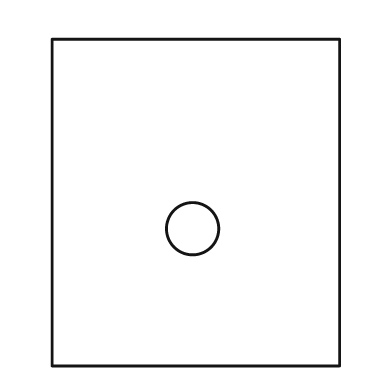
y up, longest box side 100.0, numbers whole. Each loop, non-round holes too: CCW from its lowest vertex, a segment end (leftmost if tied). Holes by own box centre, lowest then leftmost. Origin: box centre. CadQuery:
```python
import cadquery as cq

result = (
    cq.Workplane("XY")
    .moveTo(-44.0, -50.0)
    .lineTo(44.0, -50.0)
    .lineTo(44.0, 50.0)
    .lineTo(-44.0, 50.0)
    .close()
    .moveTo(-1.0, -8.0)
    .circle(8.0)
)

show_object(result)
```